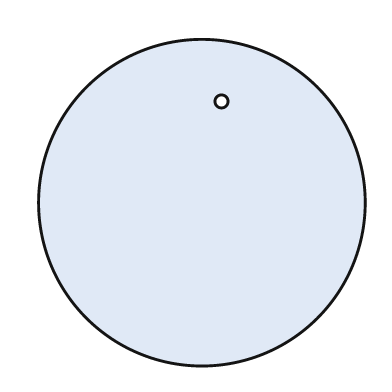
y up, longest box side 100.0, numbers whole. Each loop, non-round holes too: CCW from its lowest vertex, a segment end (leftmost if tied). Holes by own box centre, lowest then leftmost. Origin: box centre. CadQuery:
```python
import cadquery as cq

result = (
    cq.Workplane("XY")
    .moveTo(0.0, 0.0)
    .circle(50.0)
    .moveTo(6.0, 31.0)
    .circle(2.0)
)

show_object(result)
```